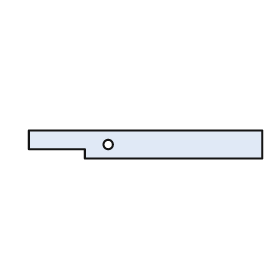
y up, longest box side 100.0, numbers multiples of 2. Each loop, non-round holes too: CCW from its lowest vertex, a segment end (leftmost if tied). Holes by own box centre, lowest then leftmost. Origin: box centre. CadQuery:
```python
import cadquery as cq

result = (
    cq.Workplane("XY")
    .moveTo(-26.0, -6.0)
    .lineTo(50.0, -6.0)
    .lineTo(50.0, 6.0)
    .lineTo(-50.0, 6.0)
    .lineTo(-50.0, -2.0)
    .lineTo(-26.0, -2.0)
    .close()
    .moveTo(-16.0, 0.0)
    .circle(2.0)
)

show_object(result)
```